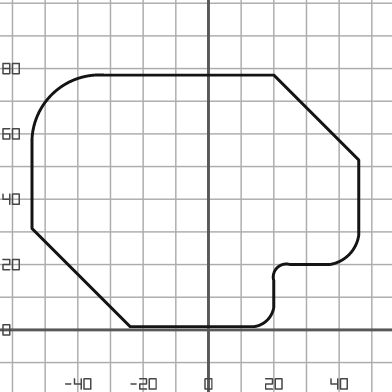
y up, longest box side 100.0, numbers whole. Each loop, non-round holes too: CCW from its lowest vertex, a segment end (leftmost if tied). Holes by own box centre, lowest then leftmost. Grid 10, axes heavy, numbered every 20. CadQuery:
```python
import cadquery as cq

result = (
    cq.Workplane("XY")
    .moveTo(-24.0, 1.0)
    .lineTo(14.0, 1.0)
    .threePointArc((18.0, 3.0), (20.0, 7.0))
    .lineTo(20.0, 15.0)
    .threePointArc((21.0, 19.0), (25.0, 20.0))
    .lineTo(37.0, 20.0)
    .threePointArc((43.0, 23.0), (46.0, 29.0))
    .lineTo(46.0, 52.0)
    .lineTo(20.0, 78.0)
    .lineTo(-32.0, 78.0)
    .threePointArc((-48.0, 72.0), (-54.0, 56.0))
    .lineTo(-54.0, 31.0)
    .close()
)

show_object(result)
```